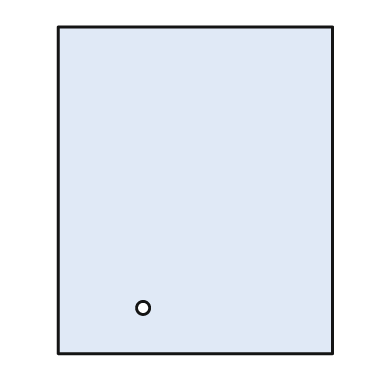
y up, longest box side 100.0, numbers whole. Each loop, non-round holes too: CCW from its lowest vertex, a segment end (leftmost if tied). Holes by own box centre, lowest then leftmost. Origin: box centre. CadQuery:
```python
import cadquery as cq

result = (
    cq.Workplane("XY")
    .moveTo(-42.0, -50.0)
    .lineTo(42.0, -50.0)
    .lineTo(42.0, 50.0)
    .lineTo(-42.0, 50.0)
    .close()
    .moveTo(-16.0, -36.0)
    .circle(2.0)
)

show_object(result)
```